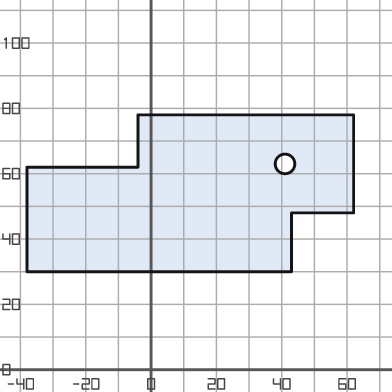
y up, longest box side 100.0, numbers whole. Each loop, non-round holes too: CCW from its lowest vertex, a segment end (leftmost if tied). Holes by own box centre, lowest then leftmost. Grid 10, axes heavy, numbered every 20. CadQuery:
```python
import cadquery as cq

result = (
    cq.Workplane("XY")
    .moveTo(-38.0, 30.0)
    .lineTo(43.0, 30.0)
    .lineTo(43.0, 48.0)
    .lineTo(62.0, 48.0)
    .lineTo(62.0, 78.0)
    .lineTo(-4.0, 78.0)
    .lineTo(-4.0, 62.0)
    .lineTo(-38.0, 62.0)
    .close()
    .moveTo(41.0, 63.0)
    .circle(3.0)
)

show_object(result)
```